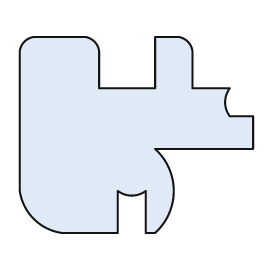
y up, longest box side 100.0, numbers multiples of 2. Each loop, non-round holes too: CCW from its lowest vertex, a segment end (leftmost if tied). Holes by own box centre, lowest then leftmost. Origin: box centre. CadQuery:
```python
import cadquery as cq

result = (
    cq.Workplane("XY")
    .moveTo(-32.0, -42.0)
    .lineTo(-8.0, -42.0)
    .lineTo(-8.0, -24.0)
    .threePointArc((-2.0, -26.0), (4.0, -24.0))
    .lineTo(4.0, -42.0)
    .lineTo(8.0, -42.0)
    .threePointArc((16.0, -24.0), (8.0, -6.0))
    .lineTo(50.0, -6.0)
    .lineTo(50.0, 8.0)
    .lineTo(40.0, 8.0)
    .threePointArc((38.0, 14.0), (40.0, 20.0))
    .lineTo(24.0, 20.0)
    .lineTo(24.0, 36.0)
    .threePointArc((22.0, 40.0), (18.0, 42.0))
    .lineTo(8.0, 42.0)
    .lineTo(8.0, 20.0)
    .lineTo(-16.0, 20.0)
    .lineTo(-16.0, 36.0)
    .threePointArc((-18.0, 40.0), (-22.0, 42.0))
    .lineTo(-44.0, 42.0)
    .threePointArc((-48.0, 40.0), (-50.0, 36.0))
    .lineTo(-50.0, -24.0)
    .threePointArc((-44.0, -36.0), (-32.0, -42.0))
    .close()
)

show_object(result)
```